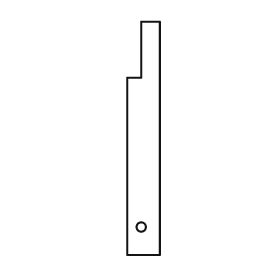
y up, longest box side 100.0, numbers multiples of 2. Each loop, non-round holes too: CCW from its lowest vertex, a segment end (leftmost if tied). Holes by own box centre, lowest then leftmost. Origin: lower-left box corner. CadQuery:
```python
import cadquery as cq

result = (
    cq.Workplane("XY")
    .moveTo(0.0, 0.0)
    .lineTo(14.0, 0.0)
    .lineTo(14.0, 100.0)
    .lineTo(6.0, 100.0)
    .lineTo(6.0, 76.0)
    .lineTo(0.0, 76.0)
    .close()
    .moveTo(6.0, 12.0)
    .circle(2.0)
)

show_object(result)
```